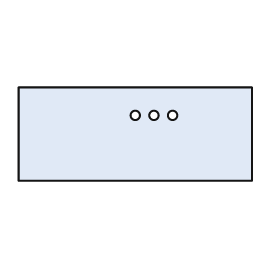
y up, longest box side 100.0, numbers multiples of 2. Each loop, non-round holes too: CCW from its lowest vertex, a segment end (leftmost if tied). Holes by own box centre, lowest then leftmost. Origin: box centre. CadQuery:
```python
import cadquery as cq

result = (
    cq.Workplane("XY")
    .moveTo(-50.0, -20.0)
    .lineTo(50.0, -20.0)
    .lineTo(50.0, 20.0)
    .lineTo(-50.0, 20.0)
    .close()
    .moveTo(0.0, 8.0)
    .circle(2.0)
    .moveTo(8.0, 8.0)
    .circle(2.0)
    .moveTo(16.0, 8.0)
    .circle(2.0)
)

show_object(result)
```